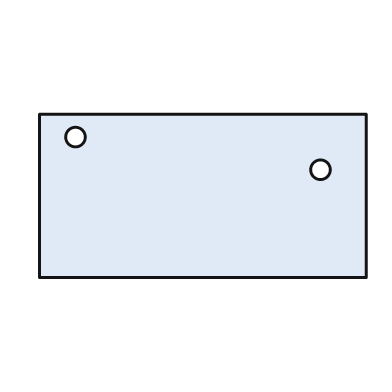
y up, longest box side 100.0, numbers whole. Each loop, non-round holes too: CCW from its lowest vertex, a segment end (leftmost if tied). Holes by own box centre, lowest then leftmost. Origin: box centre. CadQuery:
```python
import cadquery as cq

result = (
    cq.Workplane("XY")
    .moveTo(-50.0, -25.0)
    .lineTo(50.0, -25.0)
    .lineTo(50.0, 25.0)
    .lineTo(-50.0, 25.0)
    .close()
    .moveTo(36.0, 8.0)
    .circle(3.0)
    .moveTo(-39.0, 18.0)
    .circle(3.0)
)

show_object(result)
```